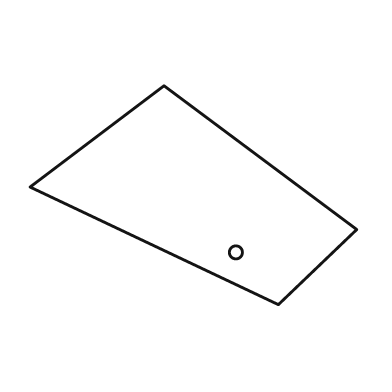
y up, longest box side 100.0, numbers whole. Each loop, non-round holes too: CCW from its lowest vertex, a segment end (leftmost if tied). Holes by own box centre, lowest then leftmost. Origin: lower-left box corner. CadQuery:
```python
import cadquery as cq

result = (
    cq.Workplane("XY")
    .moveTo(76.0, 0.0)
    .lineTo(100.0, 23.0)
    .lineTo(41.0, 67.0)
    .lineTo(0.0, 36.0)
    .close()
    .moveTo(63.0, 16.0)
    .circle(2.0)
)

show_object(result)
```